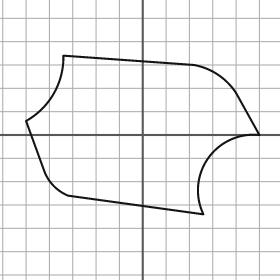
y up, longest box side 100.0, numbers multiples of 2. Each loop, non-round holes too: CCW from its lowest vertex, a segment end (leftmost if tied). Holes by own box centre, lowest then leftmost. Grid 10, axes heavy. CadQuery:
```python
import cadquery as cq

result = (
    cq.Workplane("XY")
    .moveTo(26.0, -34.0)
    .threePointArc((28.0, -10.0), (50.0, 0.0))
    .lineTo(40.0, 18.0)
    .threePointArc((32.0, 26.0), (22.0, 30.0))
    .lineTo(-34.0, 34.0)
    .threePointArc((-38.0, 18.0), (-50.0, 6.0))
    .lineTo(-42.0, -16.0)
    .threePointArc((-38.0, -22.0), (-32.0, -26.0))
    .close()
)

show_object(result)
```